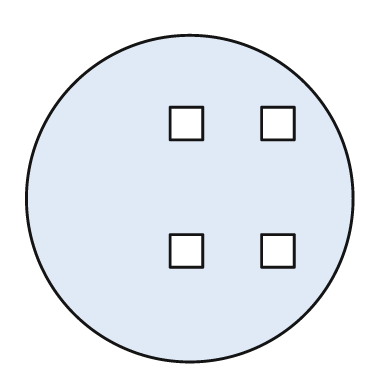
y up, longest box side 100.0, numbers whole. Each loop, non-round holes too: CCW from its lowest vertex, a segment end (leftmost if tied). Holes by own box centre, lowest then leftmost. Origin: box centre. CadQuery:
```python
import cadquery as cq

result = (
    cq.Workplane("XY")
    .moveTo(0.0, 0.0)
    .circle(50.0)
    .moveTo(-6.0, -21.0)
    .lineTo(4.0, -21.0)
    .lineTo(4.0, -11.0)
    .lineTo(-6.0, -11.0)
    .close()
    .moveTo(22.0, -21.0)
    .lineTo(32.0, -21.0)
    .lineTo(32.0, -11.0)
    .lineTo(22.0, -11.0)
    .close()
    .moveTo(-6.0, 18.0)
    .lineTo(4.0, 18.0)
    .lineTo(4.0, 28.0)
    .lineTo(-6.0, 28.0)
    .close()
    .moveTo(22.0, 18.0)
    .lineTo(32.0, 18.0)
    .lineTo(32.0, 28.0)
    .lineTo(22.0, 28.0)
    .close()
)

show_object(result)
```